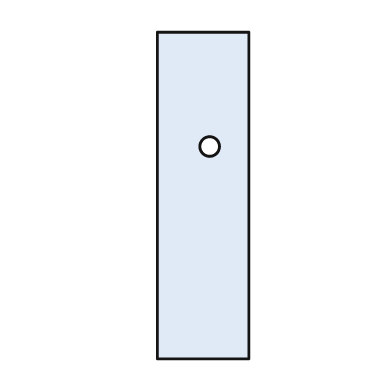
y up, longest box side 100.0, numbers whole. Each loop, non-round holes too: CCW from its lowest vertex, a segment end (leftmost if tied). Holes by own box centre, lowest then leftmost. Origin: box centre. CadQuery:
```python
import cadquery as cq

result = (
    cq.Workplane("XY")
    .moveTo(-14.0, -50.0)
    .lineTo(14.0, -50.0)
    .lineTo(14.0, 50.0)
    .lineTo(-14.0, 50.0)
    .close()
    .moveTo(2.0, 15.0)
    .circle(3.0)
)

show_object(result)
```